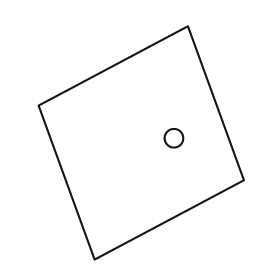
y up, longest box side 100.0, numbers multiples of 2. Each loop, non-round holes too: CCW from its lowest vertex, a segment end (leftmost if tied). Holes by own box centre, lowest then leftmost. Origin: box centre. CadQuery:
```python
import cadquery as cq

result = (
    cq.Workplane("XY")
    .moveTo(-20.0, -50.0)
    .lineTo(44.0, -16.0)
    .lineTo(20.0, 50.0)
    .lineTo(-44.0, 16.0)
    .close()
    .moveTo(14.0, 2.0)
    .circle(4.0)
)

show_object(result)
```